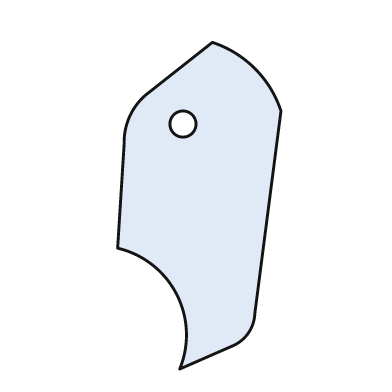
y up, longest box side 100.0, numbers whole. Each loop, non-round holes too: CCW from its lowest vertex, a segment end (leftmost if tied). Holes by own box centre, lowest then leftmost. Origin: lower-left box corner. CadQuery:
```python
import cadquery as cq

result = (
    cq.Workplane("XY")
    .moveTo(19.0, 0.0)
    .lineTo(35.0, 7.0)
    .threePointArc((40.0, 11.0), (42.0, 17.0))
    .lineTo(50.0, 79.0)
    .threePointArc((42.0, 92.0), (29.0, 100.0))
    .lineTo(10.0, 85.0)
    .threePointArc((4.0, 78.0), (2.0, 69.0))
    .lineTo(0.0, 37.0)
    .threePointArc((18.0, 23.0), (19.0, 0.0))
    .close()
    .moveTo(20.0, 75.0)
    .circle(4.0)
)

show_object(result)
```